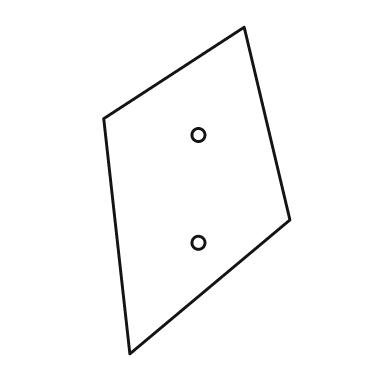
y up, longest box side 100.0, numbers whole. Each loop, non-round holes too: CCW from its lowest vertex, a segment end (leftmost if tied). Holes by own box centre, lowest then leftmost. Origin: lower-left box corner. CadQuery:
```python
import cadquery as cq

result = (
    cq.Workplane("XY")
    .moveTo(8.0, 0.0)
    .lineTo(57.0, 41.0)
    .lineTo(43.0, 100.0)
    .lineTo(0.0, 72.0)
    .close()
    .moveTo(29.0, 34.0)
    .circle(2.0)
    .moveTo(29.0, 67.0)
    .circle(2.0)
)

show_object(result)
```